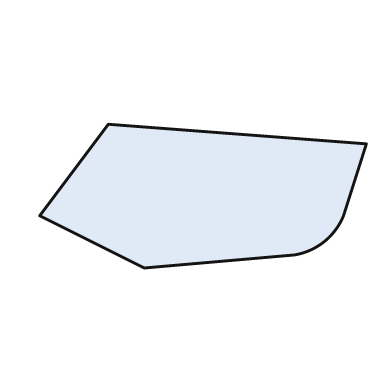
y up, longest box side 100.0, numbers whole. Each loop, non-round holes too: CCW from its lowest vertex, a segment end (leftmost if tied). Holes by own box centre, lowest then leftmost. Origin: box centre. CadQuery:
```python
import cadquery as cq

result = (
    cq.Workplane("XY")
    .moveTo(-18.0, -22.0)
    .lineTo(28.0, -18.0)
    .threePointArc((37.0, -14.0), (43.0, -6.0))
    .lineTo(50.0, 16.0)
    .lineTo(-29.0, 22.0)
    .lineTo(-50.0, -6.0)
    .close()
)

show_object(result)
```